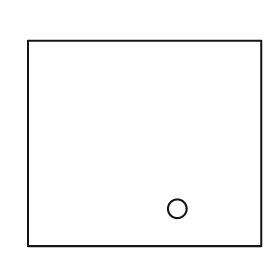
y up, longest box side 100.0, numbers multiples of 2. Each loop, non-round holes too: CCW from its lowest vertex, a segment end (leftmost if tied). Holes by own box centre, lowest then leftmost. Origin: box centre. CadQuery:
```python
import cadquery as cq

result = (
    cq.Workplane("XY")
    .moveTo(-50.0, -44.0)
    .lineTo(50.0, -44.0)
    .lineTo(50.0, 44.0)
    .lineTo(-50.0, 44.0)
    .close()
    .moveTo(14.0, -28.0)
    .circle(4.0)
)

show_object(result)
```